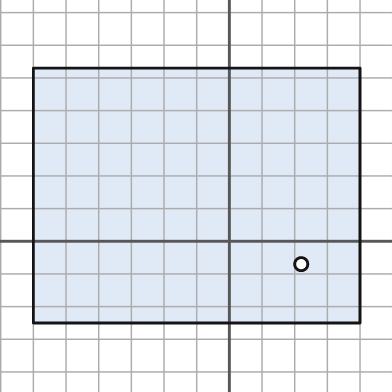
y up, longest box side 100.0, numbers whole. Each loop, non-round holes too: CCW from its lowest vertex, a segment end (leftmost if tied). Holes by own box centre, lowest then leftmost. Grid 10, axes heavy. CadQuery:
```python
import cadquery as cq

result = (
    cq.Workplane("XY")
    .moveTo(-60.0, -25.0)
    .lineTo(40.0, -25.0)
    .lineTo(40.0, 53.0)
    .lineTo(-60.0, 53.0)
    .close()
    .moveTo(22.0, -7.0)
    .circle(2.0)
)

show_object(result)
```